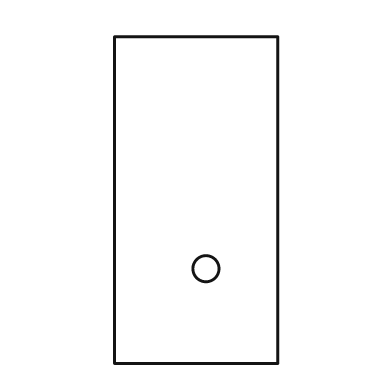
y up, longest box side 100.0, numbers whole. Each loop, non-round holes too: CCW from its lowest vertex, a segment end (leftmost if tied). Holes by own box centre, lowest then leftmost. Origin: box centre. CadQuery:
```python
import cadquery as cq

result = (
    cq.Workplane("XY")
    .moveTo(-25.0, -50.0)
    .lineTo(25.0, -50.0)
    .lineTo(25.0, 50.0)
    .lineTo(-25.0, 50.0)
    .close()
    .moveTo(3.0, -21.0)
    .circle(4.0)
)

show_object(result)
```